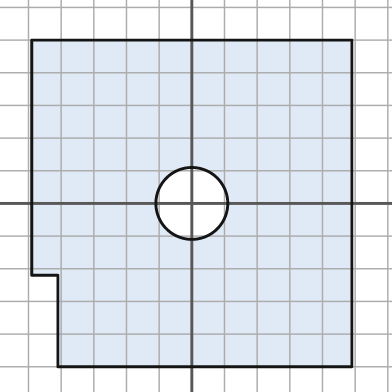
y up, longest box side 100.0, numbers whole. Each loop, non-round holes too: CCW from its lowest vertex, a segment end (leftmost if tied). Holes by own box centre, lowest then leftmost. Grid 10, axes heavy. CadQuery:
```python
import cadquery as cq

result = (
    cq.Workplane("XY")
    .moveTo(-41.0, -50.0)
    .lineTo(49.0, -50.0)
    .lineTo(49.0, 50.0)
    .lineTo(-49.0, 50.0)
    .lineTo(-49.0, -22.0)
    .lineTo(-41.0, -22.0)
    .close()
    .moveTo(0.0, 0.0)
    .circle(11.0)
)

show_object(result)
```